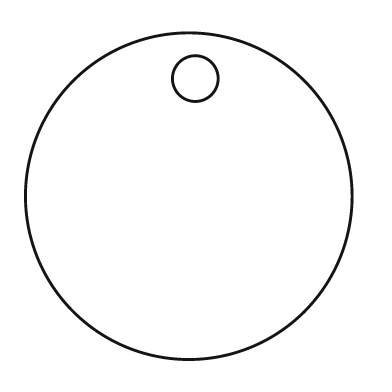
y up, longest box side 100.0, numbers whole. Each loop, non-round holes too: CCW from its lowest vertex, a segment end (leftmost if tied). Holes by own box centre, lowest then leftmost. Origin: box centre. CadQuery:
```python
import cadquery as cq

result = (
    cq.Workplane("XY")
    .moveTo(0.0, 0.0)
    .circle(50.0)
    .moveTo(2.0, 36.0)
    .circle(7.0)
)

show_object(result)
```